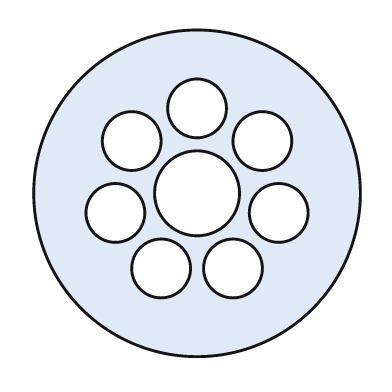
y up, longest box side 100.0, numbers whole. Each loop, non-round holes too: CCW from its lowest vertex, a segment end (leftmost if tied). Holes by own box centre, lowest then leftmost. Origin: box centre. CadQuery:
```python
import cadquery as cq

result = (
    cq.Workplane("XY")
    .moveTo(0.0, 0.0)
    .circle(50.0)
    .moveTo(-11.0, -23.0)
    .circle(9.0)
    .moveTo(11.0, -23.0)
    .circle(9.0)
    .moveTo(-25.0, -6.0)
    .circle(9.0)
    .moveTo(25.0, -6.0)
    .circle(9.0)
    .moveTo(0.0, 0.0)
    .circle(13.0)
    .moveTo(-20.0, 16.0)
    .circle(9.0)
    .moveTo(20.0, 16.0)
    .circle(9.0)
    .moveTo(0.0, 26.0)
    .circle(9.0)
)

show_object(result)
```